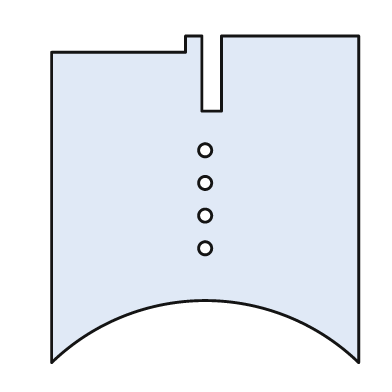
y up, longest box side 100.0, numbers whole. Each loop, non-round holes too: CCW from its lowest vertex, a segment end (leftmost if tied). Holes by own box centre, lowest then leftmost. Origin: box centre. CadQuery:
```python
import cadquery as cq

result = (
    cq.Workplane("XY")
    .moveTo(-47.0, -50.0)
    .threePointArc((0.0, -31.0), (47.0, -50.0))
    .lineTo(47.0, 50.0)
    .lineTo(5.0, 50.0)
    .lineTo(5.0, 27.0)
    .lineTo(-1.0, 27.0)
    .lineTo(-1.0, 50.0)
    .lineTo(-6.0, 50.0)
    .lineTo(-6.0, 45.0)
    .lineTo(-47.0, 45.0)
    .close()
    .moveTo(0.0, -15.0)
    .circle(2.0)
    .moveTo(0.0, -5.0)
    .circle(2.0)
    .moveTo(0.0, 5.0)
    .circle(2.0)
    .moveTo(0.0, 15.0)
    .circle(2.0)
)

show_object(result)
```